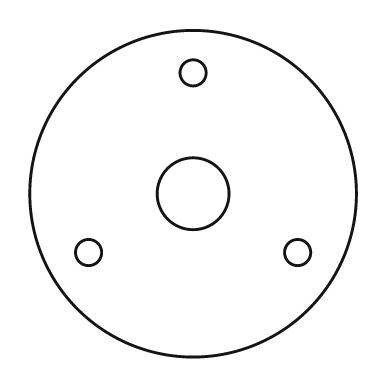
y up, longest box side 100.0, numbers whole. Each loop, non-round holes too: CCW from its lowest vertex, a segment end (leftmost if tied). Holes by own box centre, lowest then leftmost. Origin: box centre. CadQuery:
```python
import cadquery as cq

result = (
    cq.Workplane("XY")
    .moveTo(0.0, 0.0)
    .circle(50.0)
    .moveTo(-32.0, -18.0)
    .circle(4.0)
    .moveTo(32.0, -18.0)
    .circle(4.0)
    .moveTo(0.0, 0.0)
    .circle(11.0)
    .moveTo(0.0, 37.0)
    .circle(4.0)
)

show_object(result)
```